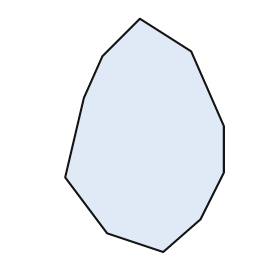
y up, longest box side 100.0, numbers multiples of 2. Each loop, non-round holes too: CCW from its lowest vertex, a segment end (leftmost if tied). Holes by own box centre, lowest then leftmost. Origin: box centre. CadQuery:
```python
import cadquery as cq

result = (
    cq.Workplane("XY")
    .moveTo(8.0, -50.0)
    .lineTo(24.0, -36.0)
    .lineTo(34.0, -16.0)
    .lineTo(34.0, 4.0)
    .lineTo(20.0, 36.0)
    .lineTo(-2.0, 50.0)
    .lineTo(-18.0, 34.0)
    .lineTo(-26.0, 16.0)
    .lineTo(-34.0, -18.0)
    .lineTo(-16.0, -42.0)
    .close()
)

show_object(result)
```